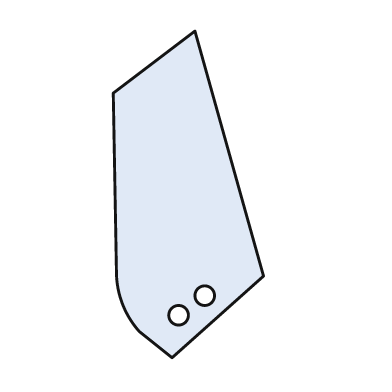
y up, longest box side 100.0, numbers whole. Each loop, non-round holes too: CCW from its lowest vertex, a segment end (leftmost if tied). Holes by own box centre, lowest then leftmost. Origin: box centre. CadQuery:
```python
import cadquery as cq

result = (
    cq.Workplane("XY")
    .moveTo(-5.0, -50.0)
    .lineTo(23.0, -25.0)
    .lineTo(2.0, 50.0)
    .lineTo(-23.0, 31.0)
    .lineTo(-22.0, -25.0)
    .threePointArc((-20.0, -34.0), (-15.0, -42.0))
    .close()
    .moveTo(-3.0, -37.0)
    .circle(3.0)
    .moveTo(5.0, -31.0)
    .circle(3.0)
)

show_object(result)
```